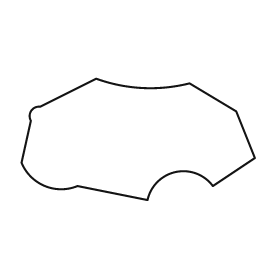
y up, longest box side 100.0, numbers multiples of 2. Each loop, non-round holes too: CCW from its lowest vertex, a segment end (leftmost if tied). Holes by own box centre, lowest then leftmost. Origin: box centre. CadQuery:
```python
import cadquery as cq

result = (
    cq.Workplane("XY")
    .moveTo(4.0, -26.0)
    .threePointArc((16.0, -14.0), (32.0, -20.0))
    .lineTo(50.0, -8.0)
    .lineTo(42.0, 12.0)
    .lineTo(22.0, 24.0)
    .threePointArc((2.0, 22.0), (-18.0, 26.0))
    .lineTo(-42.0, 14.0)
    .threePointArc((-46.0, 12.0), (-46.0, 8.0))
    .lineTo(-50.0, -10.0)
    .threePointArc((-40.0, -20.0), (-26.0, -20.0))
    .close()
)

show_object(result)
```